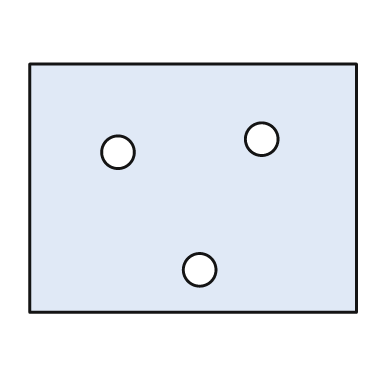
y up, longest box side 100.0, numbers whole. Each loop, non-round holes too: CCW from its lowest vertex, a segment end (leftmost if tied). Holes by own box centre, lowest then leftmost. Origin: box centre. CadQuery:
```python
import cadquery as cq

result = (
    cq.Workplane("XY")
    .moveTo(-50.0, -38.0)
    .lineTo(50.0, -38.0)
    .lineTo(50.0, 38.0)
    .lineTo(-50.0, 38.0)
    .close()
    .moveTo(2.0, -25.0)
    .circle(5.0)
    .moveTo(-23.0, 11.0)
    .circle(5.0)
    .moveTo(21.0, 15.0)
    .circle(5.0)
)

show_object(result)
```